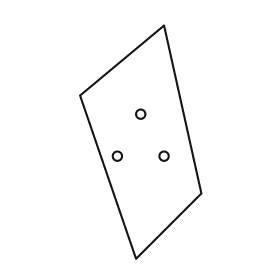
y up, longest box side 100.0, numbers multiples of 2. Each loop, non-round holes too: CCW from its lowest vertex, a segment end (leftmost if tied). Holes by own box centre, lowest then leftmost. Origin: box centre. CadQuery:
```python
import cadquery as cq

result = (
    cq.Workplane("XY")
    .moveTo(-2.0, -50.0)
    .lineTo(26.0, -22.0)
    .lineTo(10.0, 50.0)
    .lineTo(-26.0, 20.0)
    .close()
    .moveTo(-10.0, -6.0)
    .circle(2.0)
    .moveTo(10.0, -6.0)
    .circle(2.0)
    .moveTo(0.0, 12.0)
    .circle(2.0)
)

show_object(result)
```